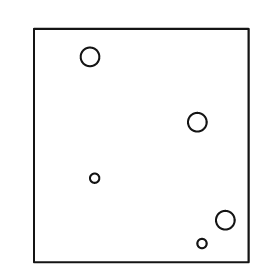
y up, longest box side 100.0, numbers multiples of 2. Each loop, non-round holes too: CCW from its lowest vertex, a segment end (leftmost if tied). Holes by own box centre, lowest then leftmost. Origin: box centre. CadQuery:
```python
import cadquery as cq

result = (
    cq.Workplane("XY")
    .moveTo(-46.0, -50.0)
    .lineTo(46.0, -50.0)
    .lineTo(46.0, 50.0)
    .lineTo(-46.0, 50.0)
    .close()
    .moveTo(26.0, -42.0)
    .circle(2.0)
    .moveTo(36.0, -32.0)
    .circle(4.0)
    .moveTo(-20.0, -14.0)
    .circle(2.0)
    .moveTo(24.0, 10.0)
    .circle(4.0)
    .moveTo(-22.0, 38.0)
    .circle(4.0)
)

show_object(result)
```